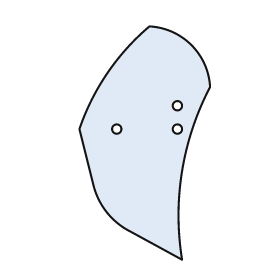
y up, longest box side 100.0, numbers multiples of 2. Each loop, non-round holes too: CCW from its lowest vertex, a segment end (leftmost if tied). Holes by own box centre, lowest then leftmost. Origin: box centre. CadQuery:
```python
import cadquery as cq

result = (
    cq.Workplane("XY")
    .moveTo(16.0, -50.0)
    .threePointArc((16.0, -12.0), (28.0, 24.0))
    .threePointArc((20.0, 42.0), (2.0, 50.0))
    .threePointArc((-16.0, 30.0), (-28.0, 6.0))
    .lineTo(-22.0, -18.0)
    .threePointArc((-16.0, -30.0), (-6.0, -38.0))
    .close()
    .moveTo(-12.0, 6.0)
    .circle(2.0)
    .moveTo(14.0, 6.0)
    .circle(2.0)
    .moveTo(14.0, 16.0)
    .circle(2.0)
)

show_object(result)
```